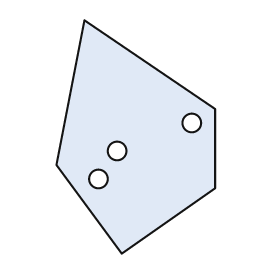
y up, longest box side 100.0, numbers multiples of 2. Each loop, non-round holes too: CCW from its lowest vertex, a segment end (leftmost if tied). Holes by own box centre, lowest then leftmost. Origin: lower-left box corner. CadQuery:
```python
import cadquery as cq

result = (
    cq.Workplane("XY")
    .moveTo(28.0, 0.0)
    .lineTo(68.0, 28.0)
    .lineTo(68.0, 62.0)
    .lineTo(12.0, 100.0)
    .lineTo(0.0, 38.0)
    .close()
    .moveTo(18.0, 32.0)
    .circle(4.0)
    .moveTo(26.0, 44.0)
    .circle(4.0)
    .moveTo(58.0, 56.0)
    .circle(4.0)
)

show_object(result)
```